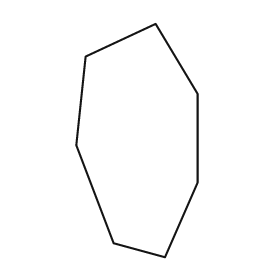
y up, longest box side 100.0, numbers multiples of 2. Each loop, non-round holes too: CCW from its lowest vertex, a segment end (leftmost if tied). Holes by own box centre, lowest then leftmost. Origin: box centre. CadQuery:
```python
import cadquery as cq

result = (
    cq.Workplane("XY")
    .moveTo(12.0, -50.0)
    .lineTo(26.0, -18.0)
    .lineTo(26.0, 20.0)
    .lineTo(8.0, 50.0)
    .lineTo(-22.0, 36.0)
    .lineTo(-26.0, -2.0)
    .lineTo(-10.0, -44.0)
    .close()
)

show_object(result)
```